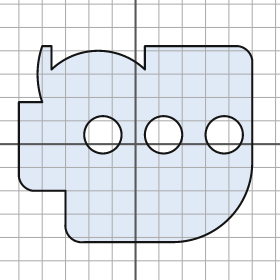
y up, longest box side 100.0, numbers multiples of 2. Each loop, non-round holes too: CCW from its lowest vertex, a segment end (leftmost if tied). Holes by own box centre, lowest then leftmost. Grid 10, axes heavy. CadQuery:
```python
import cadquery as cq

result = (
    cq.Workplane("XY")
    .moveTo(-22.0, -42.0)
    .lineTo(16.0, -42.0)
    .threePointArc((40.0, -32.0), (50.0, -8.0))
    .lineTo(50.0, 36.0)
    .threePointArc((48.0, 40.0), (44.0, 42.0))
    .lineTo(4.0, 42.0)
    .lineTo(4.0, 32.0)
    .threePointArc((-16.0, 40.0), (-36.0, 32.0))
    .lineTo(-36.0, 42.0)
    .lineTo(-40.0, 42.0)
    .threePointArc((-42.0, 30.0), (-40.0, 18.0))
    .lineTo(-50.0, 18.0)
    .lineTo(-50.0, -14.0)
    .threePointArc((-48.0, -18.0), (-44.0, -20.0))
    .lineTo(-30.0, -20.0)
    .lineTo(-30.0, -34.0)
    .threePointArc((-28.0, -40.0), (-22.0, -42.0))
    .close()
    .moveTo(-14.0, 4.0)
    .circle(8.0)
    .moveTo(12.0, 4.0)
    .circle(8.0)
    .moveTo(38.0, 4.0)
    .circle(8.0)
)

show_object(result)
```